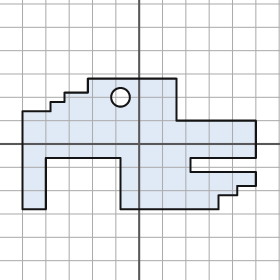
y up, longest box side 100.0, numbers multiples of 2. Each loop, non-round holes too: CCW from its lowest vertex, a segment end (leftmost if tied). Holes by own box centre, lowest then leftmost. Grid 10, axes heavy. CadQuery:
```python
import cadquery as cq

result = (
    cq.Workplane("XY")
    .moveTo(-50.0, -28.0)
    .lineTo(-40.0, -28.0)
    .lineTo(-40.0, -6.0)
    .lineTo(-8.0, -6.0)
    .lineTo(-8.0, -28.0)
    .lineTo(34.0, -28.0)
    .lineTo(34.0, -22.0)
    .lineTo(42.0, -22.0)
    .lineTo(42.0, -18.0)
    .lineTo(50.0, -18.0)
    .lineTo(50.0, -12.0)
    .lineTo(22.0, -12.0)
    .lineTo(22.0, -6.0)
    .lineTo(50.0, -6.0)
    .lineTo(50.0, 10.0)
    .lineTo(16.0, 10.0)
    .lineTo(16.0, 28.0)
    .lineTo(-22.0, 28.0)
    .lineTo(-22.0, 22.0)
    .lineTo(-32.0, 22.0)
    .lineTo(-32.0, 18.0)
    .lineTo(-38.0, 18.0)
    .lineTo(-38.0, 14.0)
    .lineTo(-50.0, 14.0)
    .close()
    .moveTo(-8.0, 20.0)
    .circle(4.0)
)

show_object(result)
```